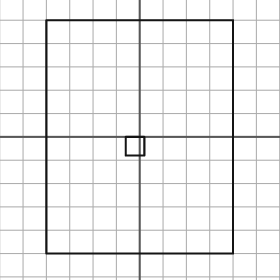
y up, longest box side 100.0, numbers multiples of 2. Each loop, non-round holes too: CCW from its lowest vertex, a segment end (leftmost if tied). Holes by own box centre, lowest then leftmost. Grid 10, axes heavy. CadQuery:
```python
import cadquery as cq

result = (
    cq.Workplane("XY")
    .moveTo(-40.0, -50.0)
    .lineTo(40.0, -50.0)
    .lineTo(40.0, 50.0)
    .lineTo(-40.0, 50.0)
    .close()
    .moveTo(-6.0, -8.0)
    .lineTo(2.0, -8.0)
    .lineTo(2.0, 0.0)
    .lineTo(-6.0, 0.0)
    .close()
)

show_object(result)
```